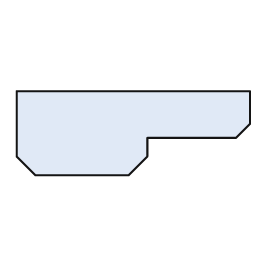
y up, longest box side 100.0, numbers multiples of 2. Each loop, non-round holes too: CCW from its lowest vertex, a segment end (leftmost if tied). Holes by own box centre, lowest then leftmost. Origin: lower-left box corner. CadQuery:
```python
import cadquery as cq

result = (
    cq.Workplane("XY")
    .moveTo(8.0, 0.0)
    .lineTo(48.0, 0.0)
    .lineTo(56.0, 8.0)
    .lineTo(56.0, 16.0)
    .lineTo(94.0, 16.0)
    .lineTo(100.0, 22.0)
    .lineTo(100.0, 36.0)
    .lineTo(0.0, 36.0)
    .lineTo(0.0, 8.0)
    .close()
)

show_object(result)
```